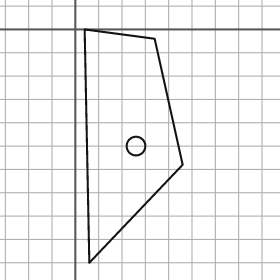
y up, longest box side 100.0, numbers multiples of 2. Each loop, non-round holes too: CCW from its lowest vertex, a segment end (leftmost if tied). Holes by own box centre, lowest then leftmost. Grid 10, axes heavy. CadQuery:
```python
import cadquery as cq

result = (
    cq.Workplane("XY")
    .moveTo(6.0, -100.0)
    .lineTo(46.0, -58.0)
    .lineTo(34.0, -4.0)
    .lineTo(4.0, 0.0)
    .close()
    .moveTo(26.0, -50.0)
    .circle(4.0)
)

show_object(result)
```